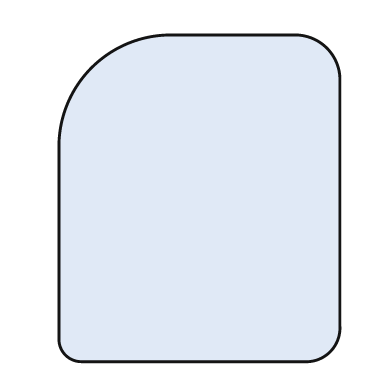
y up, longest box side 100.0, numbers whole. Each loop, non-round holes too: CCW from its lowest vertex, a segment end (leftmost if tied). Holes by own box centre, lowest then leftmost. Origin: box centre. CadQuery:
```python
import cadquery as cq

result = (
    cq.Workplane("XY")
    .moveTo(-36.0, -50.0)
    .lineTo(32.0, -50.0)
    .threePointArc((40.0, -47.0), (43.0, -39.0))
    .lineTo(43.0, 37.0)
    .threePointArc((39.0, 46.0), (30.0, 50.0))
    .lineTo(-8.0, 50.0)
    .threePointArc((-33.0, 40.0), (-43.0, 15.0))
    .lineTo(-43.0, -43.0)
    .threePointArc((-41.0, -48.0), (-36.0, -50.0))
    .close()
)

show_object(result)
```